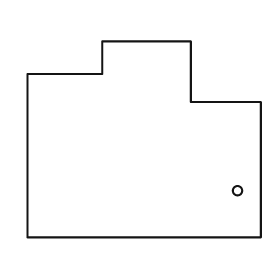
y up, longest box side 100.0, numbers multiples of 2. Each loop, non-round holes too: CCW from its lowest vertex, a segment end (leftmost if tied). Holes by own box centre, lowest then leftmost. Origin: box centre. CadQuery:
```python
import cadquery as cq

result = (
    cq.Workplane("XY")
    .moveTo(-50.0, -42.0)
    .lineTo(50.0, -42.0)
    .lineTo(50.0, 16.0)
    .lineTo(20.0, 16.0)
    .lineTo(20.0, 42.0)
    .lineTo(-18.0, 42.0)
    .lineTo(-18.0, 28.0)
    .lineTo(-50.0, 28.0)
    .close()
    .moveTo(40.0, -22.0)
    .circle(2.0)
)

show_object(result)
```